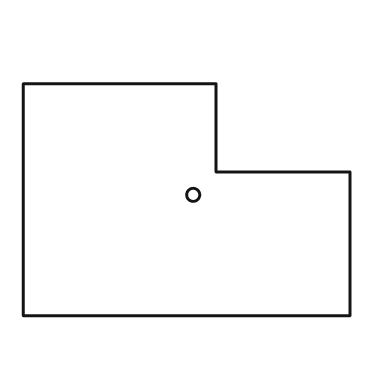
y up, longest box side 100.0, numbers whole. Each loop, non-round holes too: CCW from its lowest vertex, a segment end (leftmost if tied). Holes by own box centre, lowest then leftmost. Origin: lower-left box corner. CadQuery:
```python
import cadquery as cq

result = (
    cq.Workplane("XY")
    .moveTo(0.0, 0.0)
    .lineTo(100.0, 0.0)
    .lineTo(100.0, 44.0)
    .lineTo(59.0, 44.0)
    .lineTo(59.0, 71.0)
    .lineTo(0.0, 71.0)
    .close()
    .moveTo(52.0, 37.0)
    .circle(2.0)
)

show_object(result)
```